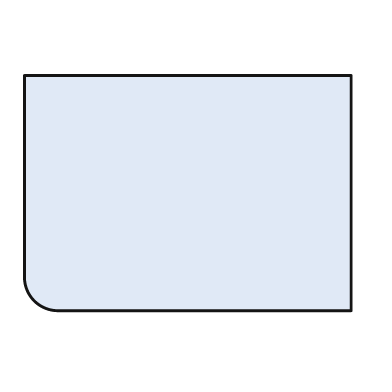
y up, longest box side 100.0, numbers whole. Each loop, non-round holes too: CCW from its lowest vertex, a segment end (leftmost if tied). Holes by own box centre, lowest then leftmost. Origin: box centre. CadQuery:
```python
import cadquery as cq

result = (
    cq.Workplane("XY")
    .moveTo(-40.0, -36.0)
    .lineTo(50.0, -36.0)
    .lineTo(50.0, 36.0)
    .lineTo(-50.0, 36.0)
    .lineTo(-50.0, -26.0)
    .threePointArc((-47.0, -33.0), (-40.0, -36.0))
    .close()
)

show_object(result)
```